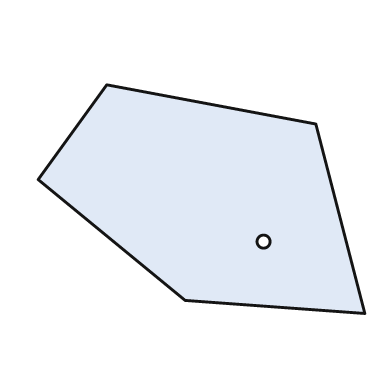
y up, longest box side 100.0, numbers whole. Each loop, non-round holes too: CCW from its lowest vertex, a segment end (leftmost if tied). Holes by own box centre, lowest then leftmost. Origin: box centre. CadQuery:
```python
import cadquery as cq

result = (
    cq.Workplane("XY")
    .moveTo(50.0, -35.0)
    .lineTo(35.0, 23.0)
    .lineTo(-29.0, 35.0)
    .lineTo(-50.0, 6.0)
    .lineTo(-5.0, -31.0)
    .close()
    .moveTo(19.0, -13.0)
    .circle(2.0)
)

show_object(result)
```